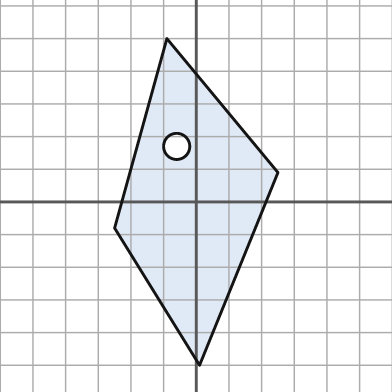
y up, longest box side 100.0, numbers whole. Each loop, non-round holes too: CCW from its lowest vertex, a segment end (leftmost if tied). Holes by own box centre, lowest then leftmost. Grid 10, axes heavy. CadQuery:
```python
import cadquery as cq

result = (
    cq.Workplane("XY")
    .moveTo(1.0, -50.0)
    .lineTo(25.0, 9.0)
    .lineTo(-9.0, 50.0)
    .lineTo(-25.0, -8.0)
    .close()
    .moveTo(-6.0, 17.0)
    .circle(4.0)
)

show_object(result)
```